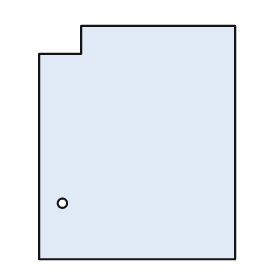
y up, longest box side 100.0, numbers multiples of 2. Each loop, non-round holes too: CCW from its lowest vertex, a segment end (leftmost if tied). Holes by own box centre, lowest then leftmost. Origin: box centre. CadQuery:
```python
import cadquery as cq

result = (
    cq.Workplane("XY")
    .moveTo(-42.0, -50.0)
    .lineTo(42.0, -50.0)
    .lineTo(42.0, 50.0)
    .lineTo(-24.0, 50.0)
    .lineTo(-24.0, 38.0)
    .lineTo(-42.0, 38.0)
    .close()
    .moveTo(-32.0, -26.0)
    .circle(2.0)
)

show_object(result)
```